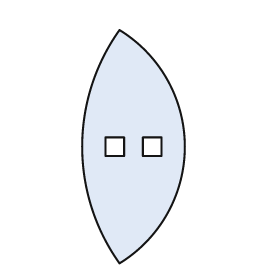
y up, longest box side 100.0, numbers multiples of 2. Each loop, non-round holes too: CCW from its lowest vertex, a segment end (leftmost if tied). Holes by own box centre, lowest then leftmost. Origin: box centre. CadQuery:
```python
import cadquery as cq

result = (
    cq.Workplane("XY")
    .moveTo(-6.0, -50.0)
    .threePointArc((22.0, 0.0), (-6.0, 50.0))
    .threePointArc((-22.0, 0.0), (-6.0, -50.0))
    .close()
    .moveTo(-12.0, -4.0)
    .lineTo(-4.0, -4.0)
    .lineTo(-4.0, 4.0)
    .lineTo(-12.0, 4.0)
    .close()
    .moveTo(4.0, -4.0)
    .lineTo(12.0, -4.0)
    .lineTo(12.0, 4.0)
    .lineTo(4.0, 4.0)
    .close()
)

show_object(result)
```